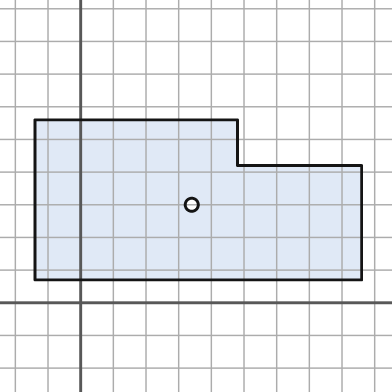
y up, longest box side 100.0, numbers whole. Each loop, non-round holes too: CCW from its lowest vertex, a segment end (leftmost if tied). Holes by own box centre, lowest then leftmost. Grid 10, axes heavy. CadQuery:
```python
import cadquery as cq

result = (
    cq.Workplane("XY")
    .moveTo(-14.0, 7.0)
    .lineTo(86.0, 7.0)
    .lineTo(86.0, 42.0)
    .lineTo(48.0, 42.0)
    .lineTo(48.0, 56.0)
    .lineTo(-14.0, 56.0)
    .close()
    .moveTo(34.0, 30.0)
    .circle(2.0)
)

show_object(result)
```